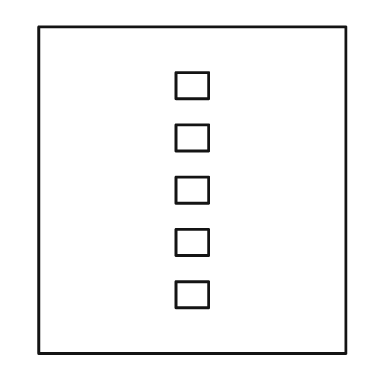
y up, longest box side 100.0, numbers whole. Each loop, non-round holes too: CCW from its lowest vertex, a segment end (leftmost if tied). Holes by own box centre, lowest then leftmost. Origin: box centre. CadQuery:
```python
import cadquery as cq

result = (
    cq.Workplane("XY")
    .moveTo(-47.0, -50.0)
    .lineTo(47.0, -50.0)
    .lineTo(47.0, 50.0)
    .lineTo(-47.0, 50.0)
    .close()
    .moveTo(-5.0, -36.0)
    .lineTo(5.0, -36.0)
    .lineTo(5.0, -28.0)
    .lineTo(-5.0, -28.0)
    .close()
    .moveTo(-5.0, -20.0)
    .lineTo(5.0, -20.0)
    .lineTo(5.0, -12.0)
    .lineTo(-5.0, -12.0)
    .close()
    .moveTo(-5.0, -4.0)
    .lineTo(5.0, -4.0)
    .lineTo(5.0, 4.0)
    .lineTo(-5.0, 4.0)
    .close()
    .moveTo(-5.0, 12.0)
    .lineTo(5.0, 12.0)
    .lineTo(5.0, 20.0)
    .lineTo(-5.0, 20.0)
    .close()
    .moveTo(-5.0, 28.0)
    .lineTo(5.0, 28.0)
    .lineTo(5.0, 36.0)
    .lineTo(-5.0, 36.0)
    .close()
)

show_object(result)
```